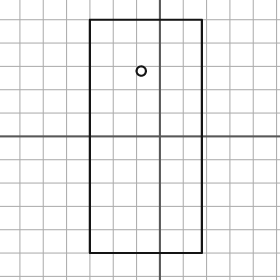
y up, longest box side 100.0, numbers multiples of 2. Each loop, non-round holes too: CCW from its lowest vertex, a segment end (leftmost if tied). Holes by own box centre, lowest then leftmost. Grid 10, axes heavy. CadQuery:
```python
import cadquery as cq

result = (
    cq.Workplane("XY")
    .moveTo(-30.0, -50.0)
    .lineTo(18.0, -50.0)
    .lineTo(18.0, 50.0)
    .lineTo(-30.0, 50.0)
    .close()
    .moveTo(-8.0, 28.0)
    .circle(2.0)
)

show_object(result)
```